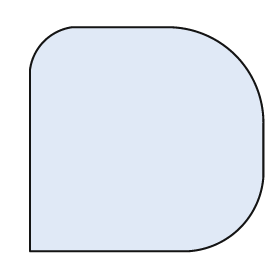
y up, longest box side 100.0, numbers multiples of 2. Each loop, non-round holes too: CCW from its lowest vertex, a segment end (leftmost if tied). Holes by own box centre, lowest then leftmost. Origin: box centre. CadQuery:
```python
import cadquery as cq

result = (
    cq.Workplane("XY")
    .moveTo(-50.0, -48.0)
    .lineTo(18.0, -48.0)
    .threePointArc((40.0, -38.0), (50.0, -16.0))
    .lineTo(50.0, 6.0)
    .threePointArc((38.0, 36.0), (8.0, 48.0))
    .lineTo(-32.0, 48.0)
    .threePointArc((-44.0, 42.0), (-50.0, 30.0))
    .close()
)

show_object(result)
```